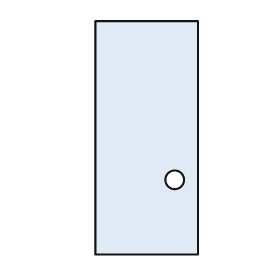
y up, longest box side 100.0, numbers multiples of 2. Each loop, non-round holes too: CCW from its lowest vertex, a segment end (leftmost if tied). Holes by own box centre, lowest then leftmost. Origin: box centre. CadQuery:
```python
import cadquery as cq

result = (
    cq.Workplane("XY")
    .moveTo(-22.0, -50.0)
    .lineTo(22.0, -50.0)
    .lineTo(22.0, 50.0)
    .lineTo(-22.0, 50.0)
    .close()
    .moveTo(12.0, -18.0)
    .circle(4.0)
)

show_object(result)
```